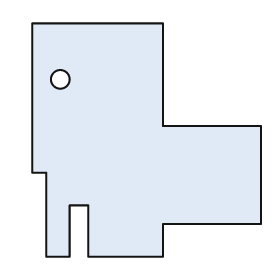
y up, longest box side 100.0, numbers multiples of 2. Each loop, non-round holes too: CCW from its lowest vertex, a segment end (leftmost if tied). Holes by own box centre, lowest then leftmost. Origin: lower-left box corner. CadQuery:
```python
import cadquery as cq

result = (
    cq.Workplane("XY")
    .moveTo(6.0, 0.0)
    .lineTo(16.0, 0.0)
    .lineTo(16.0, 22.0)
    .lineTo(24.0, 22.0)
    .lineTo(24.0, 0.0)
    .lineTo(56.0, 0.0)
    .lineTo(56.0, 14.0)
    .lineTo(98.0, 14.0)
    .lineTo(98.0, 56.0)
    .lineTo(56.0, 56.0)
    .lineTo(56.0, 100.0)
    .lineTo(0.0, 100.0)
    .lineTo(0.0, 36.0)
    .lineTo(6.0, 36.0)
    .close()
    .moveTo(12.0, 76.0)
    .circle(4.0)
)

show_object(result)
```